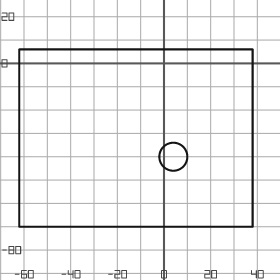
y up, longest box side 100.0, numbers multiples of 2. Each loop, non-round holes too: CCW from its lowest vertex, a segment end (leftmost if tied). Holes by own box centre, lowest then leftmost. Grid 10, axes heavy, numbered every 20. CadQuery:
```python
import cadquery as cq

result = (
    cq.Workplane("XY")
    .moveTo(-62.0, -70.0)
    .lineTo(38.0, -70.0)
    .lineTo(38.0, 6.0)
    .lineTo(-62.0, 6.0)
    .close()
    .moveTo(4.0, -40.0)
    .circle(6.0)
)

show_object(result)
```